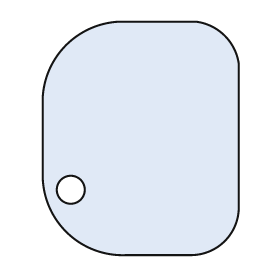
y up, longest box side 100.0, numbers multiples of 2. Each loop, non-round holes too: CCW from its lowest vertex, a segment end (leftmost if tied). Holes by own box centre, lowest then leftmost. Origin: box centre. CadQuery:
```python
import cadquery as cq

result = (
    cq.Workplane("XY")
    .moveTo(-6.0, -50.0)
    .lineTo(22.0, -50.0)
    .threePointArc((36.0, -44.0), (42.0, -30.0))
    .lineTo(42.0, 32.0)
    .threePointArc((36.0, 44.0), (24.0, 50.0))
    .lineTo(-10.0, 50.0)
    .threePointArc((-32.0, 40.0), (-42.0, 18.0))
    .lineTo(-42.0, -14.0)
    .threePointArc((-32.0, -40.0), (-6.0, -50.0))
    .close()
    .moveTo(-30.0, -22.0)
    .circle(6.0)
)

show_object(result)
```